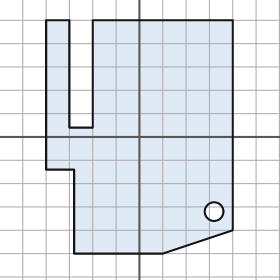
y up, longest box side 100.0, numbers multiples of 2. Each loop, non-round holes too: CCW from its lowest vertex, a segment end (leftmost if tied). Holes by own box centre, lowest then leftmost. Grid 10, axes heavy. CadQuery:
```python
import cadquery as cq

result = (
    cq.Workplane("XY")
    .moveTo(-28.0, -50.0)
    .lineTo(10.0, -50.0)
    .lineTo(40.0, -40.0)
    .lineTo(40.0, 50.0)
    .lineTo(-20.0, 50.0)
    .lineTo(-20.0, 4.0)
    .lineTo(-30.0, 4.0)
    .lineTo(-30.0, 50.0)
    .lineTo(-40.0, 50.0)
    .lineTo(-40.0, -14.0)
    .lineTo(-28.0, -14.0)
    .close()
    .moveTo(32.0, -32.0)
    .circle(4.0)
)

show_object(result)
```